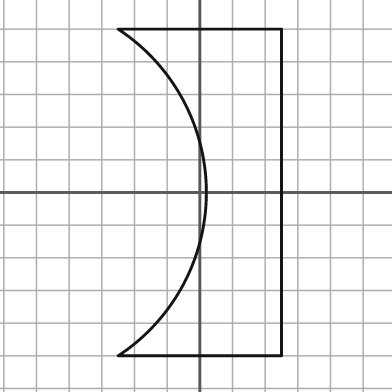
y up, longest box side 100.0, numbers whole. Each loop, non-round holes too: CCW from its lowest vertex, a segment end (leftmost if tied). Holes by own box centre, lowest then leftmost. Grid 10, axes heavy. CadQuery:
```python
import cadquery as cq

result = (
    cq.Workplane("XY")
    .moveTo(-25.0, -50.0)
    .lineTo(25.0, -50.0)
    .lineTo(25.0, 50.0)
    .lineTo(-25.0, 50.0)
    .threePointArc((2.0, 0.0), (-25.0, -50.0))
    .close()
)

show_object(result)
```